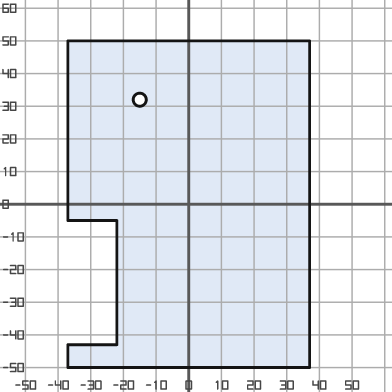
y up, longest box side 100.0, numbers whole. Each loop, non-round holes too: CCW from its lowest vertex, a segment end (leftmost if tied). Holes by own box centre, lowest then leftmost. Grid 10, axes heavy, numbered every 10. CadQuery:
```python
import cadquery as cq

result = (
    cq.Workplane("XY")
    .moveTo(-37.0, -50.0)
    .lineTo(37.0, -50.0)
    .lineTo(37.0, 50.0)
    .lineTo(-37.0, 50.0)
    .lineTo(-37.0, -5.0)
    .lineTo(-22.0, -5.0)
    .lineTo(-22.0, -43.0)
    .lineTo(-37.0, -43.0)
    .close()
    .moveTo(-15.0, 32.0)
    .circle(2.0)
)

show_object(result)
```